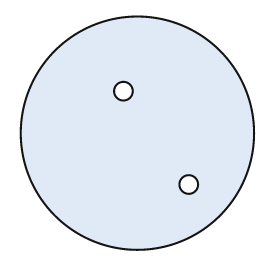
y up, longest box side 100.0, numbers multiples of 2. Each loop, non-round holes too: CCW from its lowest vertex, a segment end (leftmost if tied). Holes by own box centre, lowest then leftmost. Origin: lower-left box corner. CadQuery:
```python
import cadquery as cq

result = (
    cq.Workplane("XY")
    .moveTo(50.0, 50.0)
    .circle(50.0)
    .moveTo(72.0, 28.0)
    .circle(4.0)
    .moveTo(44.0, 68.0)
    .circle(4.0)
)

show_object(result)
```